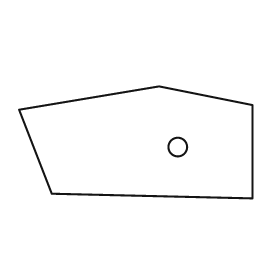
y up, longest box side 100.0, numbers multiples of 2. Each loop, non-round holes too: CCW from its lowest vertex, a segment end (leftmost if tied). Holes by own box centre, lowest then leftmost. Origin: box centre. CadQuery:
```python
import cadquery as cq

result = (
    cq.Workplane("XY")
    .moveTo(50.0, -24.0)
    .lineTo(50.0, 16.0)
    .lineTo(10.0, 24.0)
    .lineTo(-50.0, 14.0)
    .lineTo(-36.0, -22.0)
    .close()
    .moveTo(18.0, -2.0)
    .circle(4.0)
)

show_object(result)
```